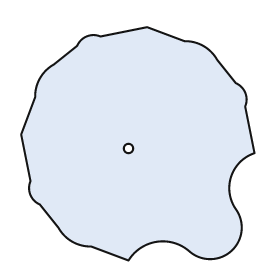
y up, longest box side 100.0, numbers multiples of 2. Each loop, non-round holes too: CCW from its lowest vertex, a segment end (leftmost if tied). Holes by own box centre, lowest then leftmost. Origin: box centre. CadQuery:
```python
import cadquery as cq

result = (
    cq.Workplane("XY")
    .moveTo(-4.0, -50.0)
    .threePointArc((8.0, -42.0), (22.0, -46.0))
    .threePointArc((40.0, -46.0), (42.0, -28.0))
    .threePointArc((40.0, -14.0), (50.0, -4.0))
    .lineTo(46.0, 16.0)
    .threePointArc((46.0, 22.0), (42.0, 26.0))
    .lineTo(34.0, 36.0)
    .threePointArc((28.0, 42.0), (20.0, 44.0))
    .lineTo(4.0, 50.0)
    .lineTo(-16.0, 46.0)
    .threePointArc((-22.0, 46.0), (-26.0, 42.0))
    .lineTo(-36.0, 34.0)
    .threePointArc((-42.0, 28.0), (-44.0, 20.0))
    .lineTo(-50.0, 4.0)
    .lineTo(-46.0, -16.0)
    .threePointArc((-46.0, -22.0), (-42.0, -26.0))
    .lineTo(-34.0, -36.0)
    .threePointArc((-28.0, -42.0), (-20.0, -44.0))
    .close()
    .moveTo(-4.0, -2.0)
    .circle(2.0)
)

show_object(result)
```